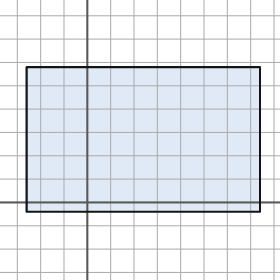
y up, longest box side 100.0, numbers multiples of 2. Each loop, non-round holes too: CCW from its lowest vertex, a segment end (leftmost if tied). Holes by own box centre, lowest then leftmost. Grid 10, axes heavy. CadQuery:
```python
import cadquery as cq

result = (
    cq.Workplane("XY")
    .moveTo(-26.0, -4.0)
    .lineTo(74.0, -4.0)
    .lineTo(74.0, 58.0)
    .lineTo(-26.0, 58.0)
    .close()
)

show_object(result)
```